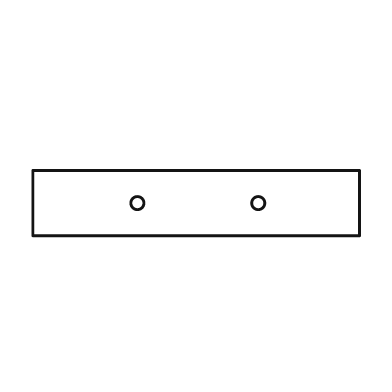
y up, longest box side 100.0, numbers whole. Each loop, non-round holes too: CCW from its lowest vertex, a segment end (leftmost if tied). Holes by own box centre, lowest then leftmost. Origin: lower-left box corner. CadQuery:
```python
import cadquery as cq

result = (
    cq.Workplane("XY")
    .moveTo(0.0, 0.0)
    .lineTo(100.0, 0.0)
    .lineTo(100.0, 20.0)
    .lineTo(0.0, 20.0)
    .close()
    .moveTo(32.0, 10.0)
    .circle(2.0)
    .moveTo(69.0, 10.0)
    .circle(2.0)
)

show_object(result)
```